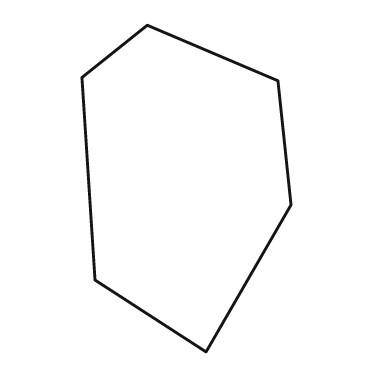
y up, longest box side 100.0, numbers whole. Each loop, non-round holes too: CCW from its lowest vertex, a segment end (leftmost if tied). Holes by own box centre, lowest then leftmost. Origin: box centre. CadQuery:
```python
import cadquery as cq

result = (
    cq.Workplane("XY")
    .moveTo(6.0, -50.0)
    .lineTo(32.0, -5.0)
    .lineTo(28.0, 33.0)
    .lineTo(-12.0, 50.0)
    .lineTo(-32.0, 34.0)
    .lineTo(-28.0, -28.0)
    .close()
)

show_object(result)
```